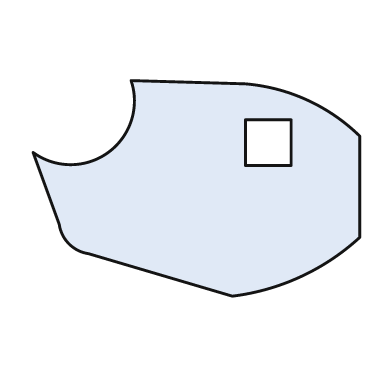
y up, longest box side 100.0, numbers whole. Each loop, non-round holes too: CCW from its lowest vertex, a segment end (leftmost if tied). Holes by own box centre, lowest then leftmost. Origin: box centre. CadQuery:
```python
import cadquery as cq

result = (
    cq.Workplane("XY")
    .moveTo(11.0, -33.0)
    .threePointArc((32.0, -27.0), (50.0, -15.0))
    .lineTo(50.0, 16.0)
    .threePointArc((34.0, 27.0), (15.0, 32.0))
    .lineTo(-20.0, 33.0)
    .threePointArc((-27.0, 11.0), (-50.0, 11.0))
    .lineTo(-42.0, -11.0)
    .threePointArc((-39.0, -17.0), (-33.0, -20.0))
    .close()
    .moveTo(15.0, 7.0)
    .lineTo(29.0, 7.0)
    .lineTo(29.0, 21.0)
    .lineTo(15.0, 21.0)
    .close()
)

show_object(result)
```